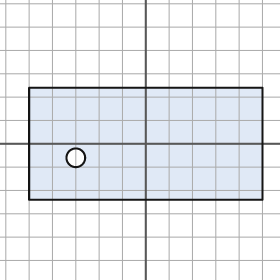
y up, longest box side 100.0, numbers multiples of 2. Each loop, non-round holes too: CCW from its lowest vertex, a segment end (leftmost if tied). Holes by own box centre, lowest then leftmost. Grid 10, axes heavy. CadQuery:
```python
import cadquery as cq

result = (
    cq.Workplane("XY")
    .moveTo(-50.0, -24.0)
    .lineTo(50.0, -24.0)
    .lineTo(50.0, 24.0)
    .lineTo(-50.0, 24.0)
    .close()
    .moveTo(-30.0, -6.0)
    .circle(4.0)
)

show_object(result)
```